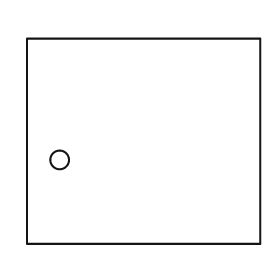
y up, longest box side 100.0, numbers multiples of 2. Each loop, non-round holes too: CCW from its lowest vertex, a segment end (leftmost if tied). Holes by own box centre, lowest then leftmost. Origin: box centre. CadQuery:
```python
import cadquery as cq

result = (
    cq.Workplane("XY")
    .moveTo(-50.0, -44.0)
    .lineTo(50.0, -44.0)
    .lineTo(50.0, 44.0)
    .lineTo(-50.0, 44.0)
    .close()
    .moveTo(-36.0, -8.0)
    .circle(4.0)
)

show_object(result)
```